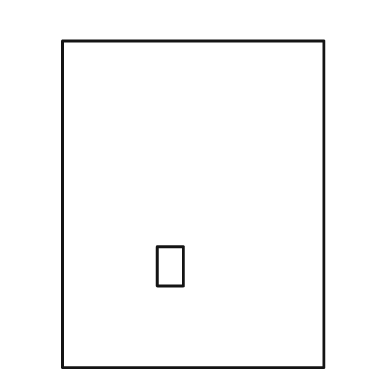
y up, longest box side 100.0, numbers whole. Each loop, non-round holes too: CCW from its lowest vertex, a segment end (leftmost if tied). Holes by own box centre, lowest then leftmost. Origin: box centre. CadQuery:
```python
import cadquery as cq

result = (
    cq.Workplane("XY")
    .moveTo(-40.0, -50.0)
    .lineTo(40.0, -50.0)
    .lineTo(40.0, 50.0)
    .lineTo(-40.0, 50.0)
    .close()
    .moveTo(-11.0, -25.0)
    .lineTo(-3.0, -25.0)
    .lineTo(-3.0, -13.0)
    .lineTo(-11.0, -13.0)
    .close()
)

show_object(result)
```